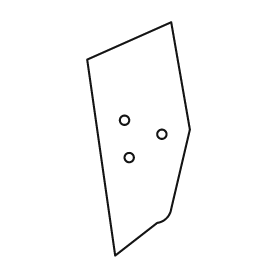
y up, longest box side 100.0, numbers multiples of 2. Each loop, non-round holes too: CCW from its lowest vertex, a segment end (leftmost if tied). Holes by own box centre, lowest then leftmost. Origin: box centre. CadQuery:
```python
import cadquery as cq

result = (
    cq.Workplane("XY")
    .moveTo(-10.0, -50.0)
    .lineTo(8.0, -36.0)
    .threePointArc((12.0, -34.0), (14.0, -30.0))
    .lineTo(22.0, 4.0)
    .lineTo(14.0, 50.0)
    .lineTo(-22.0, 34.0)
    .close()
    .moveTo(-4.0, -8.0)
    .circle(2.0)
    .moveTo(10.0, 2.0)
    .circle(2.0)
    .moveTo(-6.0, 8.0)
    .circle(2.0)
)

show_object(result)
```